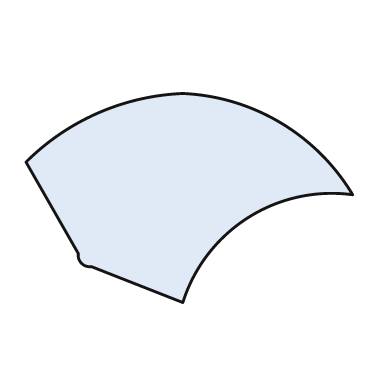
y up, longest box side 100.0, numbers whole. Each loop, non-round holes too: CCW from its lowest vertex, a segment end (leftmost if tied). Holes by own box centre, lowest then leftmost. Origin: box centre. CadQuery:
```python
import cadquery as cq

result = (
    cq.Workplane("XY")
    .moveTo(-2.0, -32.0)
    .threePointArc((18.0, -6.0), (50.0, 1.0))
    .threePointArc((28.0, 23.0), (-2.0, 32.0))
    .threePointArc((-28.0, 26.0), (-50.0, 11.0))
    .lineTo(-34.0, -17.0)
    .threePointArc((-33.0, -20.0), (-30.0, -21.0))
    .close()
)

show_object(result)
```